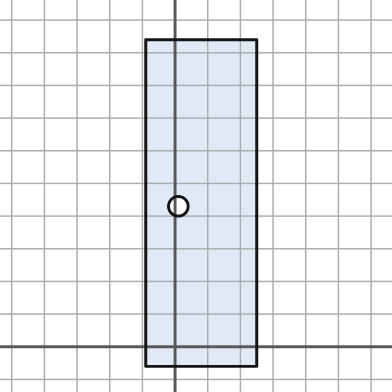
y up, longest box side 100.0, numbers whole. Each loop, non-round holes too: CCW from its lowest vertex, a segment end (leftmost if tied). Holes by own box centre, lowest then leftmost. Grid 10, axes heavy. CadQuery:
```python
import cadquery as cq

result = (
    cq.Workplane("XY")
    .moveTo(-9.0, -6.0)
    .lineTo(25.0, -6.0)
    .lineTo(25.0, 94.0)
    .lineTo(-9.0, 94.0)
    .close()
    .moveTo(1.0, 43.0)
    .circle(3.0)
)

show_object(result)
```